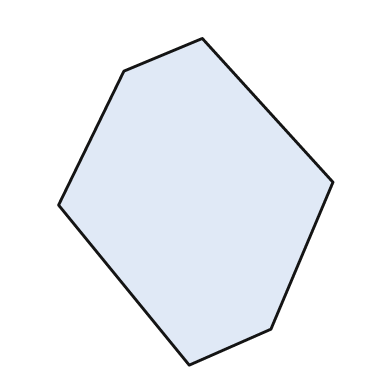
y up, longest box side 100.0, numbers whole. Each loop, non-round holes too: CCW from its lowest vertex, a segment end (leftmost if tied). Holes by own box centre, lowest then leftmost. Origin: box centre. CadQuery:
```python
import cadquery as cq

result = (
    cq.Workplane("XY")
    .moveTo(-2.0, -50.0)
    .lineTo(23.0, -39.0)
    .lineTo(42.0, 6.0)
    .lineTo(2.0, 50.0)
    .lineTo(-22.0, 40.0)
    .lineTo(-42.0, -1.0)
    .close()
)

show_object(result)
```